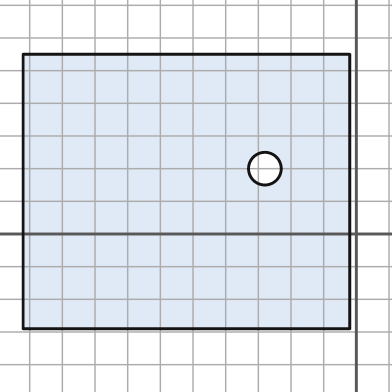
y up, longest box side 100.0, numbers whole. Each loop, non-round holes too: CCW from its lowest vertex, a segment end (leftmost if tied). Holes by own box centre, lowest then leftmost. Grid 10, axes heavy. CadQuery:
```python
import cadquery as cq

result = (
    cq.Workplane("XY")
    .moveTo(-102.0, -29.0)
    .lineTo(-2.0, -29.0)
    .lineTo(-2.0, 55.0)
    .lineTo(-102.0, 55.0)
    .close()
    .moveTo(-28.0, 20.0)
    .circle(5.0)
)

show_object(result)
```